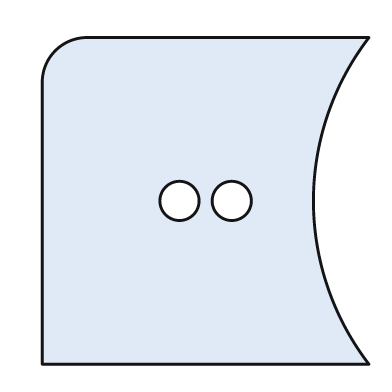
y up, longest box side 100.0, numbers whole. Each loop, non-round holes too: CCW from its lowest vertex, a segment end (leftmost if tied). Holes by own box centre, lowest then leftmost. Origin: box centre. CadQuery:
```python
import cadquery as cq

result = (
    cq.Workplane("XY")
    .moveTo(-50.0, -50.0)
    .lineTo(50.0, -50.0)
    .threePointArc((33.0, 0.0), (50.0, 50.0))
    .lineTo(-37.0, 50.0)
    .threePointArc((-46.0, 46.0), (-50.0, 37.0))
    .close()
    .moveTo(-8.0, 0.0)
    .circle(6.0)
    .moveTo(8.0, 0.0)
    .circle(6.0)
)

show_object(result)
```